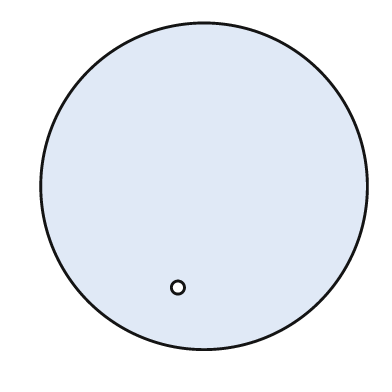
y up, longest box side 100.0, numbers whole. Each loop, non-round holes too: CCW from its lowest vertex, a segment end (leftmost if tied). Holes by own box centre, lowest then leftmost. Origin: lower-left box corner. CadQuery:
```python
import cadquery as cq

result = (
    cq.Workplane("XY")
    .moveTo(50.0, 50.0)
    .circle(50.0)
    .moveTo(42.0, 19.0)
    .circle(2.0)
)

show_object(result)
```